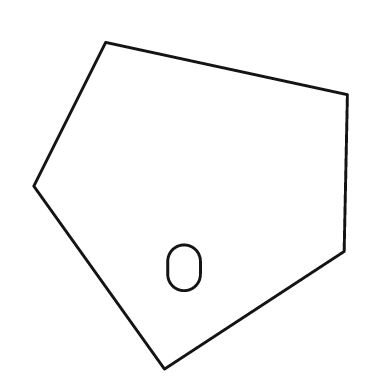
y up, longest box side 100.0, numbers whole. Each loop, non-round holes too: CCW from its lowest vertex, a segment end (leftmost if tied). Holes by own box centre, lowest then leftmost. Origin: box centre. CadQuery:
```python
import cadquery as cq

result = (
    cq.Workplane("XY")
    .moveTo(-8.0, -50.0)
    .lineTo(47.0, -14.0)
    .lineTo(48.0, 34.0)
    .lineTo(-26.0, 50.0)
    .lineTo(-48.0, 6.0)
    .close()
    .moveTo(-7.0, -21.0)
    .threePointArc((-2.0, -26.0), (3.0, -21.0))
    .lineTo(3.0, -17.0)
    .threePointArc((-2.0, -12.0), (-7.0, -17.0))
    .close()
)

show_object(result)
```